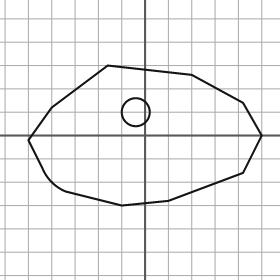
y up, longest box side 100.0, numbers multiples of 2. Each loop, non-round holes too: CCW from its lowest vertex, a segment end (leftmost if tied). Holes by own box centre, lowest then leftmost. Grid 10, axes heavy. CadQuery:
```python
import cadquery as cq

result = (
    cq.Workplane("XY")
    .moveTo(-10.0, -30.0)
    .lineTo(10.0, -28.0)
    .lineTo(42.0, -16.0)
    .lineTo(50.0, 0.0)
    .lineTo(42.0, 14.0)
    .lineTo(20.0, 26.0)
    .lineTo(-16.0, 30.0)
    .lineTo(-40.0, 12.0)
    .lineTo(-50.0, -2.0)
    .lineTo(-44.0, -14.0)
    .threePointArc((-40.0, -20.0), (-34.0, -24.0))
    .close()
    .moveTo(-4.0, 10.0)
    .circle(6.0)
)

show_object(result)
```